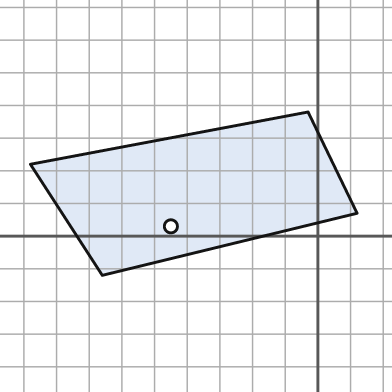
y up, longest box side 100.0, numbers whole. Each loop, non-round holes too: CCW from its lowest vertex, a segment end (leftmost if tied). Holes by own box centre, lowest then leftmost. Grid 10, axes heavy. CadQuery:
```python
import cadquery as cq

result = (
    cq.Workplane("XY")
    .moveTo(-66.0, -12.0)
    .lineTo(12.0, 7.0)
    .lineTo(-3.0, 38.0)
    .lineTo(-88.0, 22.0)
    .close()
    .moveTo(-45.0, 3.0)
    .circle(2.0)
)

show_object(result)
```